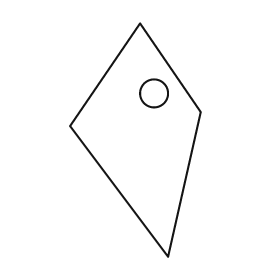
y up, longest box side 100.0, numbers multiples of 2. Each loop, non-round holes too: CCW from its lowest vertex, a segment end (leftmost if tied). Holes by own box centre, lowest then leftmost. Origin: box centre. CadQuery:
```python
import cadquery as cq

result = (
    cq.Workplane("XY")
    .moveTo(14.0, -50.0)
    .lineTo(28.0, 12.0)
    .lineTo(2.0, 50.0)
    .lineTo(-28.0, 6.0)
    .close()
    .moveTo(8.0, 20.0)
    .circle(6.0)
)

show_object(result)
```